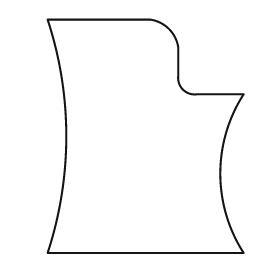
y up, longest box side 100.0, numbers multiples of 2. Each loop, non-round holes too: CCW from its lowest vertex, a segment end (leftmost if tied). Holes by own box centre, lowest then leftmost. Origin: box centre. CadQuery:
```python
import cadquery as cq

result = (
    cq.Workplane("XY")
    .moveTo(-42.0, -50.0)
    .lineTo(42.0, -50.0)
    .threePointArc((32.0, -16.0), (42.0, 18.0))
    .lineTo(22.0, 18.0)
    .threePointArc((16.0, 20.0), (14.0, 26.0))
    .lineTo(14.0, 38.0)
    .threePointArc((10.0, 46.0), (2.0, 50.0))
    .lineTo(-42.0, 50.0)
    .threePointArc((-34.0, 0.0), (-42.0, -50.0))
    .close()
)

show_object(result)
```